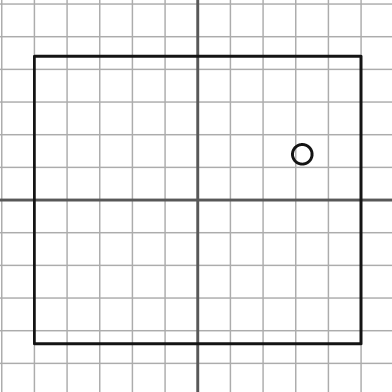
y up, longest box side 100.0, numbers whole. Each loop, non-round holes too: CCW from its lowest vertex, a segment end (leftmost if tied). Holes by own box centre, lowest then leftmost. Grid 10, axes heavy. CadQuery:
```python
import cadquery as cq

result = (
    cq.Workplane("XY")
    .moveTo(-50.0, -44.0)
    .lineTo(50.0, -44.0)
    .lineTo(50.0, 44.0)
    .lineTo(-50.0, 44.0)
    .close()
    .moveTo(32.0, 14.0)
    .circle(3.0)
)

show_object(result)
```